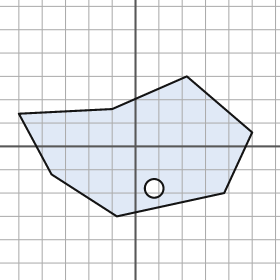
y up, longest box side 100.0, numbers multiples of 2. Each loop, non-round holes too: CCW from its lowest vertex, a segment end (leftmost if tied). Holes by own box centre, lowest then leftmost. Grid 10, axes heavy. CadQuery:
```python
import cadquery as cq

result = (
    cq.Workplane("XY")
    .moveTo(-8.0, -30.0)
    .lineTo(38.0, -20.0)
    .lineTo(50.0, 6.0)
    .lineTo(22.0, 30.0)
    .lineTo(-10.0, 16.0)
    .lineTo(-50.0, 14.0)
    .lineTo(-36.0, -12.0)
    .close()
    .moveTo(8.0, -18.0)
    .circle(4.0)
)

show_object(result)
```